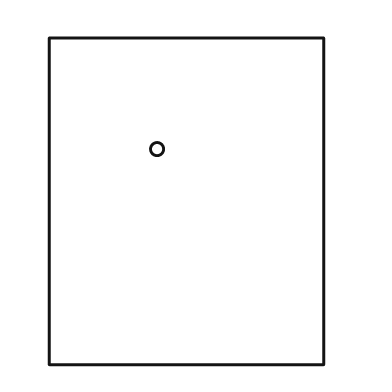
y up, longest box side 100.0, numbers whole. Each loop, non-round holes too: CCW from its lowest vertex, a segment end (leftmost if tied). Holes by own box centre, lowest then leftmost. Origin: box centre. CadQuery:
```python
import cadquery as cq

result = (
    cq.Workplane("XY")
    .moveTo(-42.0, -50.0)
    .lineTo(42.0, -50.0)
    .lineTo(42.0, 50.0)
    .lineTo(-42.0, 50.0)
    .close()
    .moveTo(-9.0, 16.0)
    .circle(2.0)
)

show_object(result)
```